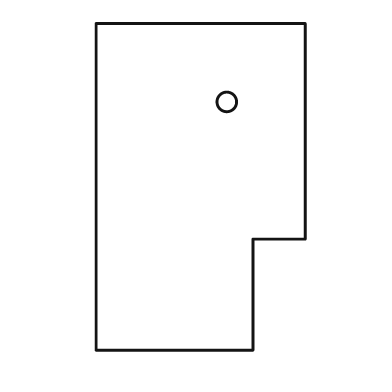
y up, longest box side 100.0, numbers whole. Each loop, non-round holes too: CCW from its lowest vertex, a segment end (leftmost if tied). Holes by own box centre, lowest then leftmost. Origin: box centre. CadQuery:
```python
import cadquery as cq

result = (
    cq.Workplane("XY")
    .moveTo(-32.0, -50.0)
    .lineTo(16.0, -50.0)
    .lineTo(16.0, -16.0)
    .lineTo(32.0, -16.0)
    .lineTo(32.0, 50.0)
    .lineTo(-32.0, 50.0)
    .close()
    .moveTo(8.0, 26.0)
    .circle(3.0)
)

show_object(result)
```